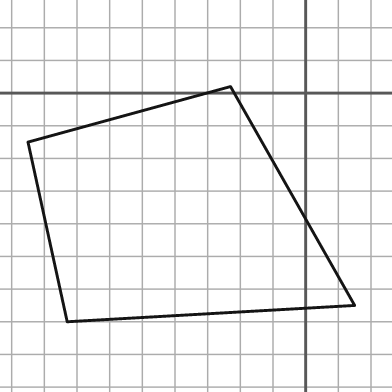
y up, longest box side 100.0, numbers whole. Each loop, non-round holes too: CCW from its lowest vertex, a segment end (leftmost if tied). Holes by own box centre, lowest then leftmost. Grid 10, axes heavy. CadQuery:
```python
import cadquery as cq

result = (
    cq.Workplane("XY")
    .moveTo(-73.0, -70.0)
    .lineTo(15.0, -65.0)
    .lineTo(-23.0, 2.0)
    .lineTo(-85.0, -15.0)
    .close()
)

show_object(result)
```